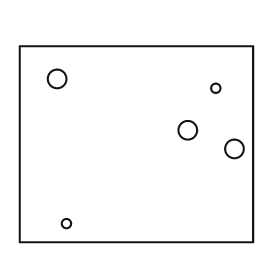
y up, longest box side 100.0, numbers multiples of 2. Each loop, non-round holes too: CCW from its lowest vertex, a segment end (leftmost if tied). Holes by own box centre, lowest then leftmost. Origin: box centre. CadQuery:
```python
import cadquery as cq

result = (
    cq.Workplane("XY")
    .moveTo(-50.0, -42.0)
    .lineTo(50.0, -42.0)
    .lineTo(50.0, 42.0)
    .lineTo(-50.0, 42.0)
    .close()
    .moveTo(-30.0, -34.0)
    .circle(2.0)
    .moveTo(42.0, -2.0)
    .circle(4.0)
    .moveTo(22.0, 6.0)
    .circle(4.0)
    .moveTo(34.0, 24.0)
    .circle(2.0)
    .moveTo(-34.0, 28.0)
    .circle(4.0)
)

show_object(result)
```